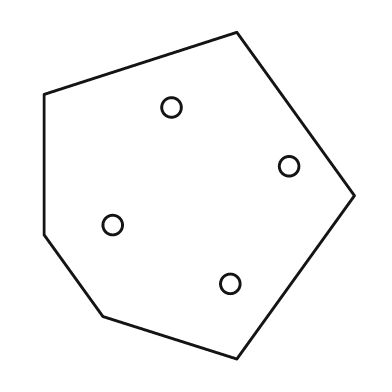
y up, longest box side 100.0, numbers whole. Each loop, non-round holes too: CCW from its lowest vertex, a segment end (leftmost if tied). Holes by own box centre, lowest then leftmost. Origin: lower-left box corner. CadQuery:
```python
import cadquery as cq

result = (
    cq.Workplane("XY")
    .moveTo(59.0, 0.0)
    .lineTo(95.0, 50.0)
    .lineTo(59.0, 100.0)
    .lineTo(0.0, 81.0)
    .lineTo(0.0, 38.0)
    .lineTo(18.0, 13.0)
    .close()
    .moveTo(57.0, 23.0)
    .circle(3.0)
    .moveTo(21.0, 41.0)
    .circle(3.0)
    .moveTo(75.0, 59.0)
    .circle(3.0)
    .moveTo(39.0, 77.0)
    .circle(3.0)
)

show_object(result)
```